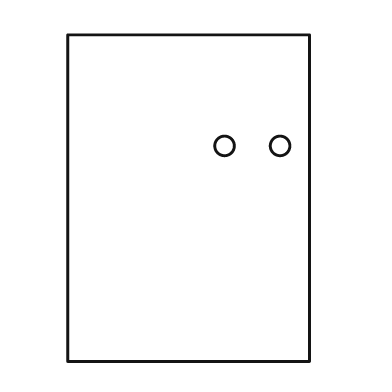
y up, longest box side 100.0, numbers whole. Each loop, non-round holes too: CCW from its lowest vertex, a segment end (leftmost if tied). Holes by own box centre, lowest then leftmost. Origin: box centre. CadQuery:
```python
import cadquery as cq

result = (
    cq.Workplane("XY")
    .moveTo(-37.0, -50.0)
    .lineTo(37.0, -50.0)
    .lineTo(37.0, 50.0)
    .lineTo(-37.0, 50.0)
    .close()
    .moveTo(11.0, 16.0)
    .circle(3.0)
    .moveTo(28.0, 16.0)
    .circle(3.0)
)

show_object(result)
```